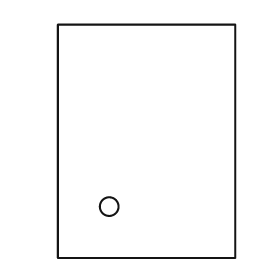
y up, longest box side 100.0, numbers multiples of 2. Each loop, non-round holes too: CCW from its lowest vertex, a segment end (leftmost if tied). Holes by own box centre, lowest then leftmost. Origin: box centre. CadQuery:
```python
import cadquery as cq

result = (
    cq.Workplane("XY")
    .moveTo(-38.0, -50.0)
    .lineTo(38.0, -50.0)
    .lineTo(38.0, 50.0)
    .lineTo(-38.0, 50.0)
    .close()
    .moveTo(-16.0, -28.0)
    .circle(4.0)
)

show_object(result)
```